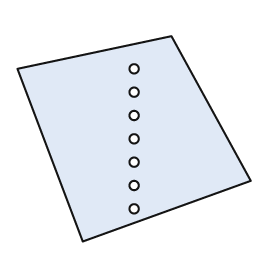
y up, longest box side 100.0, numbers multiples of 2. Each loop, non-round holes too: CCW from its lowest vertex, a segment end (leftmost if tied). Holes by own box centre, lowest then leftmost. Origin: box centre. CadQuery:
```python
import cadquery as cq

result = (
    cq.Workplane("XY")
    .moveTo(-22.0, -44.0)
    .lineTo(50.0, -18.0)
    .lineTo(16.0, 44.0)
    .lineTo(-50.0, 30.0)
    .close()
    .moveTo(0.0, -30.0)
    .circle(2.0)
    .moveTo(0.0, -20.0)
    .circle(2.0)
    .moveTo(0.0, -10.0)
    .circle(2.0)
    .moveTo(0.0, 0.0)
    .circle(2.0)
    .moveTo(0.0, 10.0)
    .circle(2.0)
    .moveTo(0.0, 20.0)
    .circle(2.0)
    .moveTo(0.0, 30.0)
    .circle(2.0)
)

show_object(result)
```